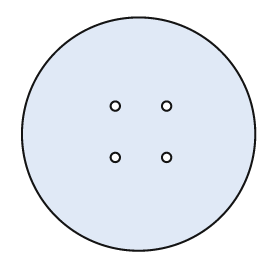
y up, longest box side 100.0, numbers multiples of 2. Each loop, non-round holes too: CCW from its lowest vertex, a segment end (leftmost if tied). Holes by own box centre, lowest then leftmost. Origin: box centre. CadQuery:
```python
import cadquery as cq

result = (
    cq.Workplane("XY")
    .moveTo(0.0, 0.0)
    .circle(50.0)
    .moveTo(-10.0, -10.0)
    .circle(2.0)
    .moveTo(12.0, -10.0)
    .circle(2.0)
    .moveTo(-10.0, 12.0)
    .circle(2.0)
    .moveTo(12.0, 12.0)
    .circle(2.0)
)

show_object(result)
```